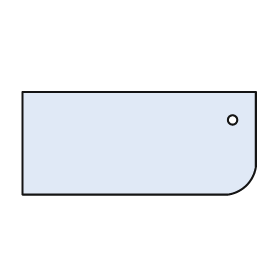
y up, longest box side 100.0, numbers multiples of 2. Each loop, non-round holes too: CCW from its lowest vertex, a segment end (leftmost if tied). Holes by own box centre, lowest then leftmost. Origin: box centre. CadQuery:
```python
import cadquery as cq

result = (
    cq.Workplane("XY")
    .moveTo(-50.0, -22.0)
    .lineTo(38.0, -22.0)
    .threePointArc((46.0, -18.0), (50.0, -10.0))
    .lineTo(50.0, 22.0)
    .lineTo(-50.0, 22.0)
    .close()
    .moveTo(40.0, 10.0)
    .circle(2.0)
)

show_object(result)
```